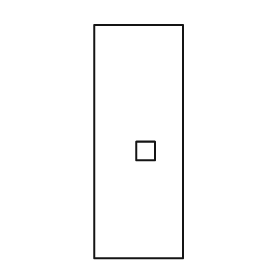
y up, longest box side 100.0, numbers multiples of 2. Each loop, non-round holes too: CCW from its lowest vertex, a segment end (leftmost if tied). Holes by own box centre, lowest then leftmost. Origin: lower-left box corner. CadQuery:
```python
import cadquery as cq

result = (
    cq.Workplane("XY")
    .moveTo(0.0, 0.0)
    .lineTo(38.0, 0.0)
    .lineTo(38.0, 100.0)
    .lineTo(0.0, 100.0)
    .close()
    .moveTo(18.0, 42.0)
    .lineTo(26.0, 42.0)
    .lineTo(26.0, 50.0)
    .lineTo(18.0, 50.0)
    .close()
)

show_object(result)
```